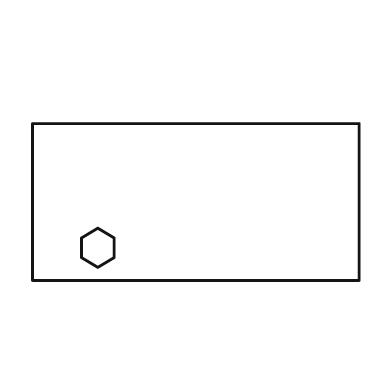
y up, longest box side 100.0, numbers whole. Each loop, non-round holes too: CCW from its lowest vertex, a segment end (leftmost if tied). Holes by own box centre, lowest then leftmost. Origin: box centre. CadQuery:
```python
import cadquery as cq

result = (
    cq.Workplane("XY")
    .moveTo(-50.0, -24.0)
    .lineTo(50.0, -24.0)
    .lineTo(50.0, 24.0)
    .lineTo(-50.0, 24.0)
    .close()
    .moveTo(-30.0, -20.0)
    .lineTo(-25.0, -17.0)
    .lineTo(-25.0, -11.0)
    .lineTo(-30.0, -8.0)
    .lineTo(-35.0, -11.0)
    .lineTo(-35.0, -17.0)
    .close()
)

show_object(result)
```